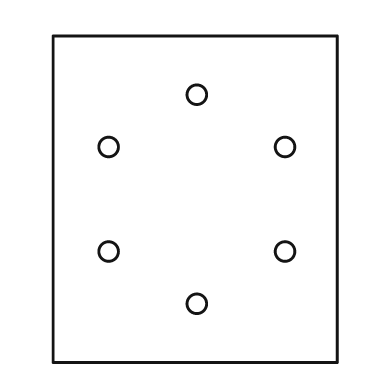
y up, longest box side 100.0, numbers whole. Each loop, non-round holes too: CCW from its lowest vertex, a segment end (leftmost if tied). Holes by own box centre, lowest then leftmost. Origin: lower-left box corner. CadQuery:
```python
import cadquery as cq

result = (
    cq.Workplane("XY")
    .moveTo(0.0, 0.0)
    .lineTo(87.0, 0.0)
    .lineTo(87.0, 100.0)
    .lineTo(0.0, 100.0)
    .close()
    .moveTo(44.0, 18.0)
    .circle(3.0)
    .moveTo(17.0, 34.0)
    .circle(3.0)
    .moveTo(71.0, 34.0)
    .circle(3.0)
    .moveTo(17.0, 66.0)
    .circle(3.0)
    .moveTo(71.0, 66.0)
    .circle(3.0)
    .moveTo(44.0, 82.0)
    .circle(3.0)
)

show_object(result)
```